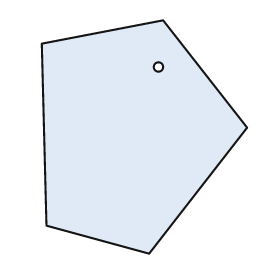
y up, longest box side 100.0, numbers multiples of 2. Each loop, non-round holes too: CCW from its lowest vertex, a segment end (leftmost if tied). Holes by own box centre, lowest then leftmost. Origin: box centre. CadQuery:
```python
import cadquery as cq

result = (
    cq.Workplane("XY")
    .moveTo(2.0, -50.0)
    .lineTo(44.0, 4.0)
    .lineTo(8.0, 50.0)
    .lineTo(-44.0, 40.0)
    .lineTo(-42.0, -38.0)
    .close()
    .moveTo(6.0, 30.0)
    .circle(2.0)
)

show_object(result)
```